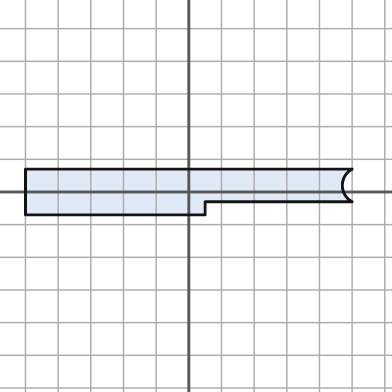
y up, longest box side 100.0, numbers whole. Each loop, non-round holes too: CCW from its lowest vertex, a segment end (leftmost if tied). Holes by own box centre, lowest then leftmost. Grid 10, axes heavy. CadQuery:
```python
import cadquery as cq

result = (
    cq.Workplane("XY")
    .moveTo(-50.0, -7.0)
    .lineTo(5.0, -7.0)
    .lineTo(5.0, -3.0)
    .lineTo(50.0, -3.0)
    .threePointArc((47.0, 2.0), (50.0, 7.0))
    .lineTo(-50.0, 7.0)
    .close()
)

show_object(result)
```